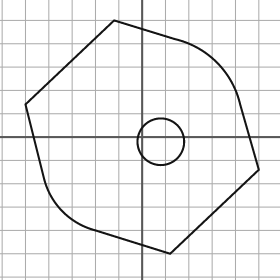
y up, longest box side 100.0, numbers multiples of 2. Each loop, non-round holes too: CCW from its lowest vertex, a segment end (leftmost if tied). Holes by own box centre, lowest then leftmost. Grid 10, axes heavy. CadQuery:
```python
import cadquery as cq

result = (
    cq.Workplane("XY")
    .moveTo(12.0, -50.0)
    .lineTo(50.0, -14.0)
    .lineTo(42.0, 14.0)
    .threePointArc((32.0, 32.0), (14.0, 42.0))
    .lineTo(-12.0, 50.0)
    .lineTo(-50.0, 14.0)
    .lineTo(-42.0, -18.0)
    .threePointArc((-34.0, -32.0), (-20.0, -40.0))
    .close()
    .moveTo(8.0, -2.0)
    .circle(10.0)
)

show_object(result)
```